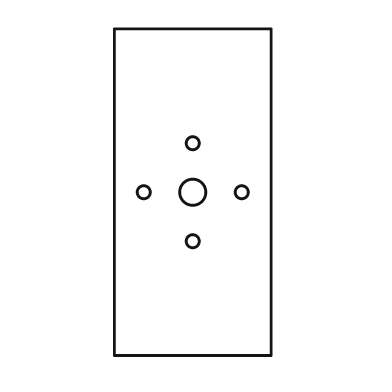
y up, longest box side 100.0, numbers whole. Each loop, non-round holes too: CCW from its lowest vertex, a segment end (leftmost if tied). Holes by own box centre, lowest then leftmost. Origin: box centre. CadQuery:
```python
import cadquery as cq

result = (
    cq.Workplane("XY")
    .moveTo(-24.0, -50.0)
    .lineTo(24.0, -50.0)
    .lineTo(24.0, 50.0)
    .lineTo(-24.0, 50.0)
    .close()
    .moveTo(0.0, -15.0)
    .circle(2.0)
    .moveTo(-15.0, 0.0)
    .circle(2.0)
    .moveTo(0.0, 0.0)
    .circle(4.0)
    .moveTo(15.0, 0.0)
    .circle(2.0)
    .moveTo(0.0, 15.0)
    .circle(2.0)
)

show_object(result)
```